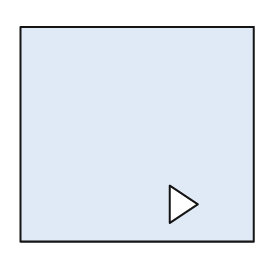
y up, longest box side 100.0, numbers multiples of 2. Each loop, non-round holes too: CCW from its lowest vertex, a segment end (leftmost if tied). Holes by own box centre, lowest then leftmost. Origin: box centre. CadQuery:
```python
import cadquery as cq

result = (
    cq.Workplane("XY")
    .moveTo(-50.0, -46.0)
    .lineTo(50.0, -46.0)
    .lineTo(50.0, 46.0)
    .lineTo(-50.0, 46.0)
    .close()
    .moveTo(14.0, -38.0)
    .lineTo(26.0, -30.0)
    .lineTo(14.0, -22.0)
    .close()
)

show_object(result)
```